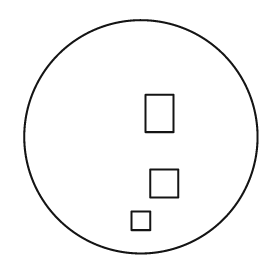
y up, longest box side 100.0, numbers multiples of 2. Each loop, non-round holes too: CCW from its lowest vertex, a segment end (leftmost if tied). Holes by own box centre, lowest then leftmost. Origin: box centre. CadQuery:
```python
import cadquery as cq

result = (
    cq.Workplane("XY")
    .moveTo(0.0, 0.0)
    .circle(50.0)
    .moveTo(-4.0, -40.0)
    .lineTo(4.0, -40.0)
    .lineTo(4.0, -32.0)
    .lineTo(-4.0, -32.0)
    .close()
    .moveTo(4.0, -26.0)
    .lineTo(16.0, -26.0)
    .lineTo(16.0, -14.0)
    .lineTo(4.0, -14.0)
    .close()
    .moveTo(2.0, 2.0)
    .lineTo(14.0, 2.0)
    .lineTo(14.0, 18.0)
    .lineTo(2.0, 18.0)
    .close()
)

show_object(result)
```